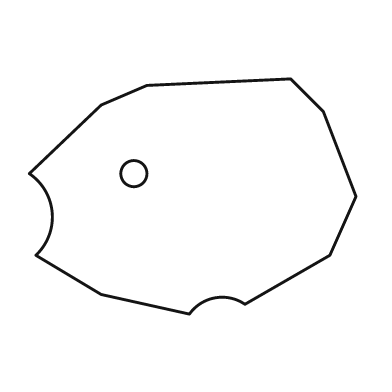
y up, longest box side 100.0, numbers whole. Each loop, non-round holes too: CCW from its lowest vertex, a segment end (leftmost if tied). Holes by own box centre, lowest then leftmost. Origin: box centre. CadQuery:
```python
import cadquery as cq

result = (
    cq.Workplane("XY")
    .moveTo(-1.0, -36.0)
    .threePointArc((7.0, -31.0), (16.0, -33.0))
    .lineTo(42.0, -18.0)
    .lineTo(50.0, 0.0)
    .lineTo(40.0, 26.0)
    .lineTo(30.0, 36.0)
    .lineTo(-14.0, 34.0)
    .lineTo(-28.0, 28.0)
    .lineTo(-50.0, 7.0)
    .threePointArc((-43.0, -5.0), (-48.0, -18.0))
    .lineTo(-28.0, -30.0)
    .close()
    .moveTo(-18.0, 7.0)
    .circle(4.0)
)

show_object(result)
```